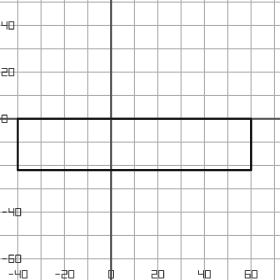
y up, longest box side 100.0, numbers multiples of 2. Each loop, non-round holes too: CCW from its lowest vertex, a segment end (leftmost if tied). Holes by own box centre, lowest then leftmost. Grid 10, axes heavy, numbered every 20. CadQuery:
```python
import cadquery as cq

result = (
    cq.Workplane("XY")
    .moveTo(-40.0, -22.0)
    .lineTo(60.0, -22.0)
    .lineTo(60.0, 0.0)
    .lineTo(-40.0, 0.0)
    .close()
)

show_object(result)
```